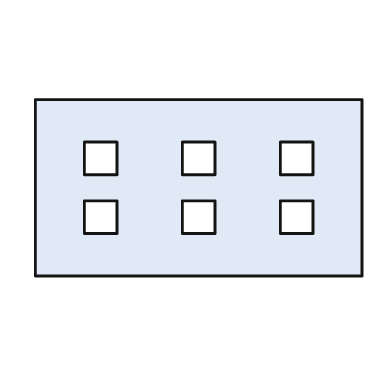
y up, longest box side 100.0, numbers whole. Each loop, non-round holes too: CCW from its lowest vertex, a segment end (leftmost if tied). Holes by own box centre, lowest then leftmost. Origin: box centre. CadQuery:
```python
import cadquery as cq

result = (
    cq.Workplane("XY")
    .moveTo(-50.0, -27.0)
    .lineTo(50.0, -27.0)
    .lineTo(50.0, 27.0)
    .lineTo(-50.0, 27.0)
    .close()
    .moveTo(-35.0, -14.0)
    .lineTo(-25.0, -14.0)
    .lineTo(-25.0, -4.0)
    .lineTo(-35.0, -4.0)
    .close()
    .moveTo(-5.0, -14.0)
    .lineTo(5.0, -14.0)
    .lineTo(5.0, -4.0)
    .lineTo(-5.0, -4.0)
    .close()
    .moveTo(25.0, -14.0)
    .lineTo(35.0, -14.0)
    .lineTo(35.0, -4.0)
    .lineTo(25.0, -4.0)
    .close()
    .moveTo(-35.0, 4.0)
    .lineTo(-25.0, 4.0)
    .lineTo(-25.0, 14.0)
    .lineTo(-35.0, 14.0)
    .close()
    .moveTo(-5.0, 4.0)
    .lineTo(5.0, 4.0)
    .lineTo(5.0, 14.0)
    .lineTo(-5.0, 14.0)
    .close()
    .moveTo(25.0, 4.0)
    .lineTo(35.0, 4.0)
    .lineTo(35.0, 14.0)
    .lineTo(25.0, 14.0)
    .close()
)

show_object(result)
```